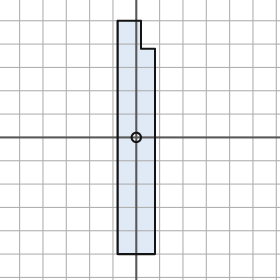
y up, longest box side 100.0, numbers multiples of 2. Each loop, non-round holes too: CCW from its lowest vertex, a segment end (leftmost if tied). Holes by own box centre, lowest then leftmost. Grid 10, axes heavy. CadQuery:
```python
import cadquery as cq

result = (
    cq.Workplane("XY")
    .moveTo(-8.0, -50.0)
    .lineTo(8.0, -50.0)
    .lineTo(8.0, 38.0)
    .lineTo(2.0, 38.0)
    .lineTo(2.0, 50.0)
    .lineTo(-8.0, 50.0)
    .close()
    .moveTo(0.0, 0.0)
    .circle(2.0)
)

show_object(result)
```